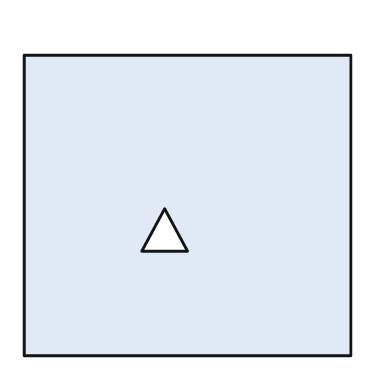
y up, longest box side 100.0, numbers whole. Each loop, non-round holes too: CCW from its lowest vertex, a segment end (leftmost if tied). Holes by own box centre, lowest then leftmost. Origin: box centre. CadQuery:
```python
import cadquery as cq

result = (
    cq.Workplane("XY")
    .moveTo(-50.0, -46.0)
    .lineTo(50.0, -46.0)
    .lineTo(50.0, 46.0)
    .lineTo(-50.0, 46.0)
    .close()
    .moveTo(-14.0, -14.0)
    .lineTo(0.0, -14.0)
    .lineTo(-7.0, -1.0)
    .close()
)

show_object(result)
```